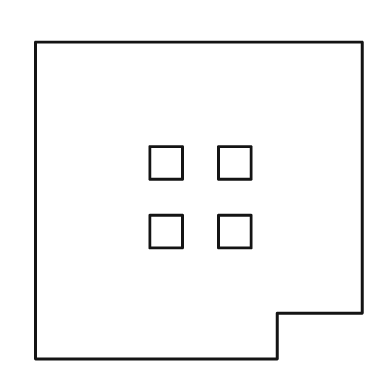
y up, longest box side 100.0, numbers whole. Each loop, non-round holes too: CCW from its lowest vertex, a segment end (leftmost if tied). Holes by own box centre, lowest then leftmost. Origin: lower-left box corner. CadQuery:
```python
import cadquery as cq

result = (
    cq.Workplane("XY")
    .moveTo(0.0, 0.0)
    .lineTo(74.0, 0.0)
    .lineTo(74.0, 14.0)
    .lineTo(100.0, 14.0)
    .lineTo(100.0, 97.0)
    .lineTo(0.0, 97.0)
    .close()
    .moveTo(35.0, 34.0)
    .lineTo(45.0, 34.0)
    .lineTo(45.0, 44.0)
    .lineTo(35.0, 44.0)
    .close()
    .moveTo(56.0, 34.0)
    .lineTo(66.0, 34.0)
    .lineTo(66.0, 44.0)
    .lineTo(56.0, 44.0)
    .close()
    .moveTo(35.0, 55.0)
    .lineTo(45.0, 55.0)
    .lineTo(45.0, 65.0)
    .lineTo(35.0, 65.0)
    .close()
    .moveTo(56.0, 55.0)
    .lineTo(66.0, 55.0)
    .lineTo(66.0, 65.0)
    .lineTo(56.0, 65.0)
    .close()
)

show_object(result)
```